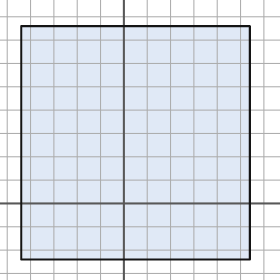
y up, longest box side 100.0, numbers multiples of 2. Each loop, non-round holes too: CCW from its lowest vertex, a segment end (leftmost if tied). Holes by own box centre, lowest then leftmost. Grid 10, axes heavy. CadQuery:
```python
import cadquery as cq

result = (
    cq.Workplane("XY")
    .moveTo(-44.0, -24.0)
    .lineTo(54.0, -24.0)
    .lineTo(54.0, 76.0)
    .lineTo(-44.0, 76.0)
    .close()
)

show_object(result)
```